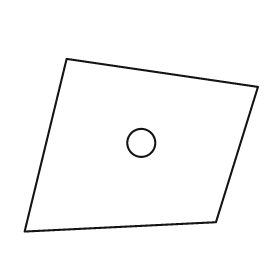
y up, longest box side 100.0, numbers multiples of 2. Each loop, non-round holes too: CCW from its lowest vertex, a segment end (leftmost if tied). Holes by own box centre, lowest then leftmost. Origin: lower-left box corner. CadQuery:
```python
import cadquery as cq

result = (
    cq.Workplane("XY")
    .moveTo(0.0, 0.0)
    .lineTo(82.0, 4.0)
    .lineTo(100.0, 62.0)
    .lineTo(18.0, 74.0)
    .close()
    .moveTo(50.0, 38.0)
    .circle(6.0)
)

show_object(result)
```